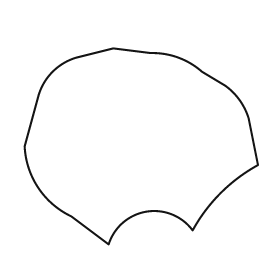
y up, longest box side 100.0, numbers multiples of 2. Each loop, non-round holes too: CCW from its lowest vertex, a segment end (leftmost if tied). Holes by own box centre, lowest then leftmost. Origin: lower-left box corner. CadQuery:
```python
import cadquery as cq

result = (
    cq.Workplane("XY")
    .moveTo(36.0, 0.0)
    .threePointArc((52.0, 14.0), (72.0, 6.0))
    .threePointArc((84.0, 22.0), (100.0, 34.0))
    .lineTo(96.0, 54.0)
    .threePointArc((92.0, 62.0), (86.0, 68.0))
    .lineTo(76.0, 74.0)
    .threePointArc((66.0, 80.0), (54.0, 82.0))
    .lineTo(38.0, 84.0)
    .lineTo(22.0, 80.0)
    .threePointArc((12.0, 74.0), (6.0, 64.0))
    .lineTo(0.0, 42.0)
    .threePointArc((6.0, 24.0), (20.0, 12.0))
    .close()
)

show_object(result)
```